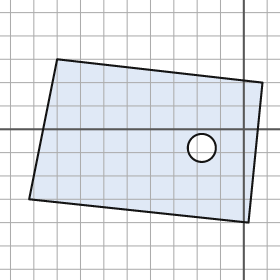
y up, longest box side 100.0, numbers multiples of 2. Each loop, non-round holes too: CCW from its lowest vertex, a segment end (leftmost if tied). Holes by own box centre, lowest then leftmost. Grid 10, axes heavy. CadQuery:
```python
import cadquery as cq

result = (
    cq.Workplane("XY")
    .moveTo(2.0, -40.0)
    .lineTo(8.0, 20.0)
    .lineTo(-80.0, 30.0)
    .lineTo(-92.0, -30.0)
    .close()
    .moveTo(-18.0, -8.0)
    .circle(6.0)
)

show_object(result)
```